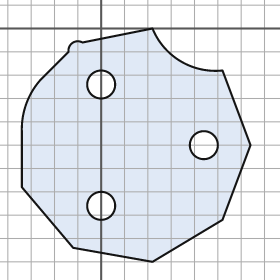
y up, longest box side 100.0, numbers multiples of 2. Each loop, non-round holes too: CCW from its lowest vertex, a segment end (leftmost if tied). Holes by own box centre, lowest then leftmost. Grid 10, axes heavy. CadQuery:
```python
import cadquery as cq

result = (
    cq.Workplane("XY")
    .moveTo(22.0, -100.0)
    .lineTo(52.0, -82.0)
    .lineTo(64.0, -50.0)
    .lineTo(52.0, -18.0)
    .threePointArc((34.0, -14.0), (22.0, 0.0))
    .lineTo(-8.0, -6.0)
    .threePointArc((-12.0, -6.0), (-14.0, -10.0))
    .lineTo(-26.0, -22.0)
    .threePointArc((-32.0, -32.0), (-34.0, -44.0))
    .lineTo(-34.0, -68.0)
    .lineTo(-12.0, -94.0)
    .close()
    .moveTo(0.0, -76.0)
    .circle(6.0)
    .moveTo(44.0, -50.0)
    .circle(6.0)
    .moveTo(0.0, -24.0)
    .circle(6.0)
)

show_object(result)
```